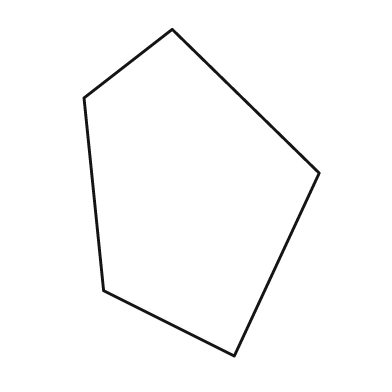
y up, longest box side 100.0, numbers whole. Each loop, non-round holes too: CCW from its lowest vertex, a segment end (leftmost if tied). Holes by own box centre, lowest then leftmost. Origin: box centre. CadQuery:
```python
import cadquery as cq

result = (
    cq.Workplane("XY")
    .moveTo(10.0, -50.0)
    .lineTo(36.0, 6.0)
    .lineTo(-9.0, 50.0)
    .lineTo(-36.0, 29.0)
    .lineTo(-30.0, -30.0)
    .close()
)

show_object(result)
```